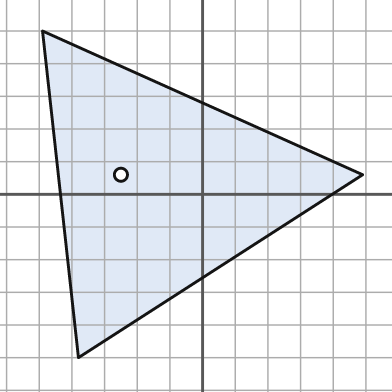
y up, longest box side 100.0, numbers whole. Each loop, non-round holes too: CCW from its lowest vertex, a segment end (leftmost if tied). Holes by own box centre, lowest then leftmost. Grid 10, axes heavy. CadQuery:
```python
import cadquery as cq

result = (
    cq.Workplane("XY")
    .moveTo(-38.0, -50.0)
    .lineTo(49.0, 6.0)
    .lineTo(-49.0, 50.0)
    .close()
    .moveTo(-25.0, 6.0)
    .circle(2.0)
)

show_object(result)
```